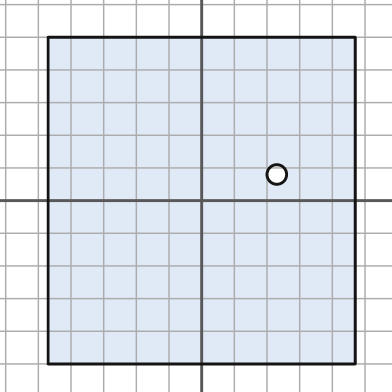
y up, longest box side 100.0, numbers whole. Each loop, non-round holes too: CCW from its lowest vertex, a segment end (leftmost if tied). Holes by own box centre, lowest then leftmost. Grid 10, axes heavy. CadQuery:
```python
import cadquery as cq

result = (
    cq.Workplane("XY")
    .moveTo(-47.0, -50.0)
    .lineTo(47.0, -50.0)
    .lineTo(47.0, 50.0)
    .lineTo(-47.0, 50.0)
    .close()
    .moveTo(23.0, 8.0)
    .circle(3.0)
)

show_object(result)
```